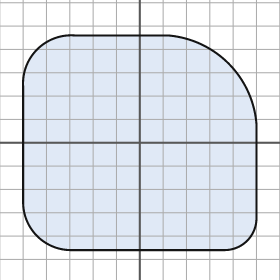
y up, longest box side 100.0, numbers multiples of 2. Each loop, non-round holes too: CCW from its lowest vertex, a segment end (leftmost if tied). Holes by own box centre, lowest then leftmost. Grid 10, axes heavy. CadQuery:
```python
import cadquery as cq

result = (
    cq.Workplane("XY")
    .moveTo(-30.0, -46.0)
    .lineTo(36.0, -46.0)
    .threePointArc((46.0, -42.0), (50.0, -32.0))
    .lineTo(50.0, 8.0)
    .threePointArc((38.0, 34.0), (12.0, 46.0))
    .lineTo(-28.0, 46.0)
    .threePointArc((-44.0, 40.0), (-50.0, 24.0))
    .lineTo(-50.0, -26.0)
    .threePointArc((-44.0, -40.0), (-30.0, -46.0))
    .close()
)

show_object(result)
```